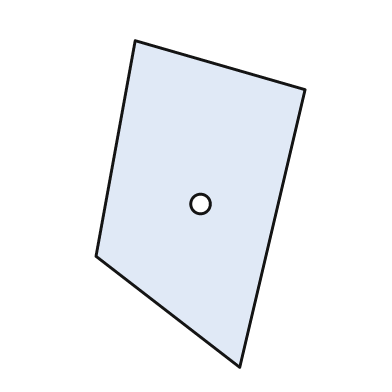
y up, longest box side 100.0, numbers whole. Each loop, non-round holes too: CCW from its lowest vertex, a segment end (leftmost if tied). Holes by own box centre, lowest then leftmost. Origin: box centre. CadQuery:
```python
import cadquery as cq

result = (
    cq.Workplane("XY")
    .moveTo(12.0, -50.0)
    .lineTo(32.0, 35.0)
    .lineTo(-20.0, 50.0)
    .lineTo(-32.0, -16.0)
    .close()
    .moveTo(0.0, 0.0)
    .circle(3.0)
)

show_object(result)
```